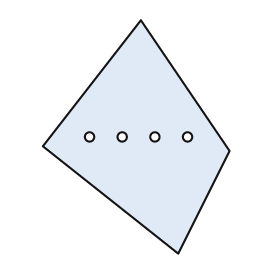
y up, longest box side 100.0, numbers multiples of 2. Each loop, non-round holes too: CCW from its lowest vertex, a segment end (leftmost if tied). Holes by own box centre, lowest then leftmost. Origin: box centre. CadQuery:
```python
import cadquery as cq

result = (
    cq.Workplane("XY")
    .moveTo(18.0, -50.0)
    .lineTo(40.0, -6.0)
    .lineTo(2.0, 50.0)
    .lineTo(-40.0, -4.0)
    .close()
    .moveTo(-20.0, 0.0)
    .circle(2.0)
    .moveTo(-6.0, 0.0)
    .circle(2.0)
    .moveTo(8.0, 0.0)
    .circle(2.0)
    .moveTo(22.0, 0.0)
    .circle(2.0)
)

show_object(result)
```